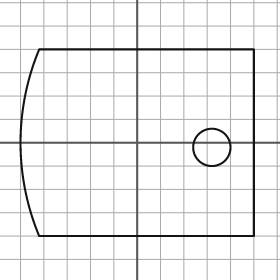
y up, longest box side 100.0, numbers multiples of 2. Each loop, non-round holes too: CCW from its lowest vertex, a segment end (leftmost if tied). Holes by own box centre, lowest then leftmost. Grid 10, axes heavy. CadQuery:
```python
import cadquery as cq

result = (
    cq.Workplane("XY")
    .moveTo(-42.0, -40.0)
    .lineTo(50.0, -40.0)
    .lineTo(50.0, 40.0)
    .lineTo(-42.0, 40.0)
    .threePointArc((-50.0, 0.0), (-42.0, -40.0))
    .close()
    .moveTo(32.0, -2.0)
    .circle(8.0)
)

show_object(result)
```